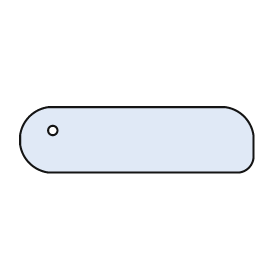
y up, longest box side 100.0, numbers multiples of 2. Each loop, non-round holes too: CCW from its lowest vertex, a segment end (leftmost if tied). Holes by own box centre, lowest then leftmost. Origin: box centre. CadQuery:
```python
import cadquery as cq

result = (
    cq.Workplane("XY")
    .moveTo(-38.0, -14.0)
    .lineTo(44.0, -14.0)
    .threePointArc((48.0, -12.0), (50.0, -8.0))
    .lineTo(50.0, 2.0)
    .threePointArc((46.0, 10.0), (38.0, 14.0))
    .lineTo(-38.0, 14.0)
    .threePointArc((-46.0, 10.0), (-50.0, 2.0))
    .lineTo(-50.0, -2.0)
    .threePointArc((-46.0, -10.0), (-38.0, -14.0))
    .close()
    .moveTo(-36.0, 4.0)
    .circle(2.0)
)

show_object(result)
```